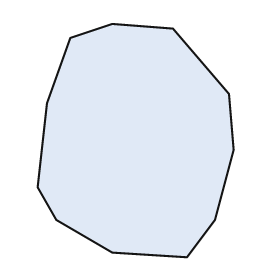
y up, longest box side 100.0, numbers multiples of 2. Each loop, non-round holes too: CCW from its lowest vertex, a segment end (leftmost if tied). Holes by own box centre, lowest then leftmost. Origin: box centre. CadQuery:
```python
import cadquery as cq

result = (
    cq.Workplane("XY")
    .moveTo(22.0, -50.0)
    .lineTo(34.0, -34.0)
    .lineTo(42.0, -4.0)
    .lineTo(40.0, 20.0)
    .lineTo(16.0, 48.0)
    .lineTo(-10.0, 50.0)
    .lineTo(-28.0, 44.0)
    .lineTo(-38.0, 16.0)
    .lineTo(-42.0, -20.0)
    .lineTo(-34.0, -34.0)
    .lineTo(-10.0, -48.0)
    .close()
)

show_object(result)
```